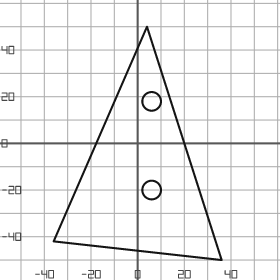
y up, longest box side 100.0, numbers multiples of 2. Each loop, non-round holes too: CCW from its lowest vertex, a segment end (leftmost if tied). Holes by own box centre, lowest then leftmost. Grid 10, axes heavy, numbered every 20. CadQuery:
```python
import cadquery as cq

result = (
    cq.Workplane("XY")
    .moveTo(36.0, -50.0)
    .lineTo(4.0, 50.0)
    .lineTo(-36.0, -42.0)
    .close()
    .moveTo(6.0, -20.0)
    .circle(4.0)
    .moveTo(6.0, 18.0)
    .circle(4.0)
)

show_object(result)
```